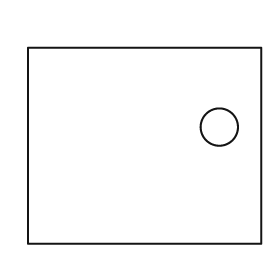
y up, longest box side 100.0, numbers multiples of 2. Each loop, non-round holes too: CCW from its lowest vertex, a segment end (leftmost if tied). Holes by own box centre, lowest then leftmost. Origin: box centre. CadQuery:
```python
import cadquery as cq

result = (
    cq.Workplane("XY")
    .moveTo(-50.0, -42.0)
    .lineTo(50.0, -42.0)
    .lineTo(50.0, 42.0)
    .lineTo(-50.0, 42.0)
    .close()
    .moveTo(32.0, 8.0)
    .circle(8.0)
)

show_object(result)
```